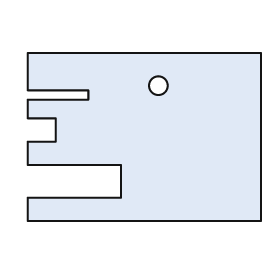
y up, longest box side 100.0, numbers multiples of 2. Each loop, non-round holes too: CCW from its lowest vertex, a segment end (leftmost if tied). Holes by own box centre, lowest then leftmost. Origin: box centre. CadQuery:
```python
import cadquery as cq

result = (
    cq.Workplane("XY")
    .moveTo(-50.0, -36.0)
    .lineTo(50.0, -36.0)
    .lineTo(50.0, 36.0)
    .lineTo(-50.0, 36.0)
    .lineTo(-50.0, 20.0)
    .lineTo(-24.0, 20.0)
    .lineTo(-24.0, 16.0)
    .lineTo(-50.0, 16.0)
    .lineTo(-50.0, 8.0)
    .lineTo(-38.0, 8.0)
    .lineTo(-38.0, -2.0)
    .lineTo(-50.0, -2.0)
    .lineTo(-50.0, -12.0)
    .lineTo(-10.0, -12.0)
    .lineTo(-10.0, -26.0)
    .lineTo(-50.0, -26.0)
    .close()
    .moveTo(6.0, 22.0)
    .circle(4.0)
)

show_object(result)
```